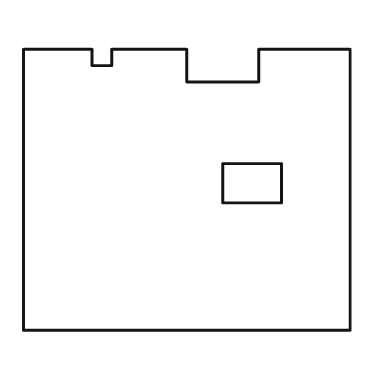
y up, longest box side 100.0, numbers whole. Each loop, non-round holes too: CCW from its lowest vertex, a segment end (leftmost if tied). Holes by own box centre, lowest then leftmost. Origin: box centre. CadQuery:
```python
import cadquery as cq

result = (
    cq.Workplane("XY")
    .moveTo(-50.0, -43.0)
    .lineTo(50.0, -43.0)
    .lineTo(50.0, 43.0)
    .lineTo(22.0, 43.0)
    .lineTo(22.0, 33.0)
    .lineTo(0.0, 33.0)
    .lineTo(0.0, 43.0)
    .lineTo(-23.0, 43.0)
    .lineTo(-23.0, 38.0)
    .lineTo(-29.0, 38.0)
    .lineTo(-29.0, 43.0)
    .lineTo(-50.0, 43.0)
    .close()
    .moveTo(11.0, -4.0)
    .lineTo(29.0, -4.0)
    .lineTo(29.0, 8.0)
    .lineTo(11.0, 8.0)
    .close()
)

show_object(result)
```